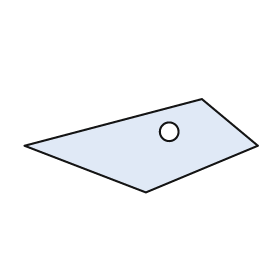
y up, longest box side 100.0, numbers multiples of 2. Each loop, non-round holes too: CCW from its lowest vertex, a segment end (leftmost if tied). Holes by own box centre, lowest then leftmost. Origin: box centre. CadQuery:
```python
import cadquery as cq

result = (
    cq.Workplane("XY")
    .moveTo(2.0, -20.0)
    .lineTo(50.0, 0.0)
    .lineTo(26.0, 20.0)
    .lineTo(-50.0, 0.0)
    .close()
    .moveTo(12.0, 6.0)
    .circle(4.0)
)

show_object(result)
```